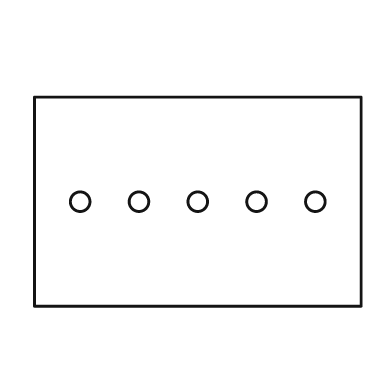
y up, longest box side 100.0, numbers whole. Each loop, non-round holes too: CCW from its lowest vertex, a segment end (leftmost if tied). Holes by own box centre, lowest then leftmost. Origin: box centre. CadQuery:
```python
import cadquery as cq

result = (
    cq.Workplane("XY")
    .moveTo(-50.0, -32.0)
    .lineTo(50.0, -32.0)
    .lineTo(50.0, 32.0)
    .lineTo(-50.0, 32.0)
    .close()
    .moveTo(-36.0, 0.0)
    .circle(3.0)
    .moveTo(-18.0, 0.0)
    .circle(3.0)
    .moveTo(0.0, 0.0)
    .circle(3.0)
    .moveTo(18.0, 0.0)
    .circle(3.0)
    .moveTo(36.0, 0.0)
    .circle(3.0)
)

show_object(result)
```